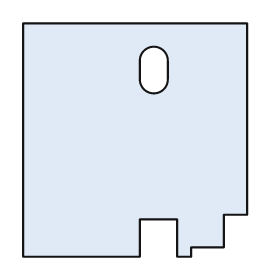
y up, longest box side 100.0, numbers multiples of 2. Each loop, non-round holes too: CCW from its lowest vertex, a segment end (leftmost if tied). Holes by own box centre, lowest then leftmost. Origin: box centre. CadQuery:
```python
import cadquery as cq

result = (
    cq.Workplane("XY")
    .moveTo(-48.0, -50.0)
    .lineTo(2.0, -50.0)
    .lineTo(2.0, -34.0)
    .lineTo(18.0, -34.0)
    .lineTo(18.0, -50.0)
    .lineTo(24.0, -50.0)
    .lineTo(24.0, -46.0)
    .lineTo(38.0, -46.0)
    .lineTo(38.0, -32.0)
    .lineTo(48.0, -32.0)
    .lineTo(48.0, 50.0)
    .lineTo(-48.0, 50.0)
    .close()
    .moveTo(2.0, 26.0)
    .threePointArc((8.0, 20.0), (14.0, 26.0))
    .lineTo(14.0, 34.0)
    .threePointArc((8.0, 40.0), (2.0, 34.0))
    .close()
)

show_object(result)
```